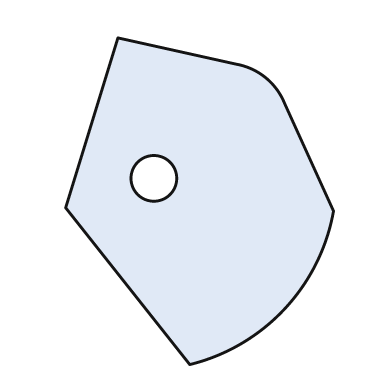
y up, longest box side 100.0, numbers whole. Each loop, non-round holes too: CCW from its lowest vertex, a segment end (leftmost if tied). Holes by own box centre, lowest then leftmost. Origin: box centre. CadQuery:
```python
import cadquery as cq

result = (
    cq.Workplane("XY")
    .moveTo(-3.0, -50.0)
    .threePointArc((26.0, -33.0), (41.0, -3.0))
    .lineTo(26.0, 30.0)
    .threePointArc((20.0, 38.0), (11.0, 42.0))
    .lineTo(-25.0, 50.0)
    .lineTo(-41.0, -2.0)
    .close()
    .moveTo(-14.0, 7.0)
    .circle(7.0)
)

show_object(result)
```